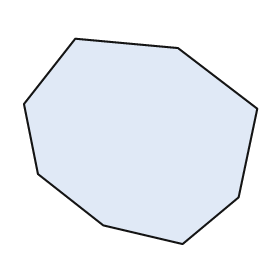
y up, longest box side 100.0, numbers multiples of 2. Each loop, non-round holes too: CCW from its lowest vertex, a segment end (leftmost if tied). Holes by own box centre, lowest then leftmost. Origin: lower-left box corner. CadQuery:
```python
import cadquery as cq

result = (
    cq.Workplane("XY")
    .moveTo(68.0, 0.0)
    .lineTo(92.0, 20.0)
    .lineTo(100.0, 58.0)
    .lineTo(66.0, 84.0)
    .lineTo(22.0, 88.0)
    .lineTo(0.0, 60.0)
    .lineTo(6.0, 30.0)
    .lineTo(34.0, 8.0)
    .close()
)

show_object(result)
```